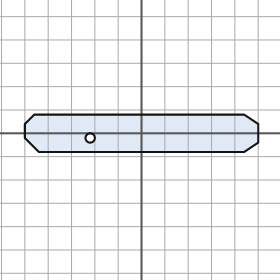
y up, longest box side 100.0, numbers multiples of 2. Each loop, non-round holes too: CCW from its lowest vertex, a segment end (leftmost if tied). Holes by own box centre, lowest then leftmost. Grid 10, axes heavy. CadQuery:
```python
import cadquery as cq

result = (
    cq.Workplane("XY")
    .moveTo(-44.0, -8.0)
    .lineTo(44.0, -8.0)
    .lineTo(50.0, -4.0)
    .lineTo(50.0, 4.0)
    .lineTo(44.0, 8.0)
    .lineTo(-46.0, 8.0)
    .lineTo(-50.0, 4.0)
    .lineTo(-50.0, -2.0)
    .close()
    .moveTo(-22.0, -2.0)
    .circle(2.0)
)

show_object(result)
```